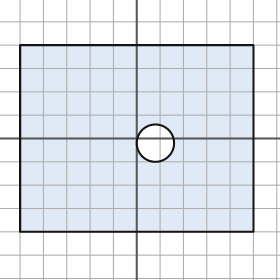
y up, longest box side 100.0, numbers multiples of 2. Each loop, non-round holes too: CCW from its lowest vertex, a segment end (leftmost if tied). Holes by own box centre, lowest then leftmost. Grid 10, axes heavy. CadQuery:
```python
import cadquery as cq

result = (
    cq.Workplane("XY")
    .moveTo(-50.0, -40.0)
    .lineTo(50.0, -40.0)
    .lineTo(50.0, 40.0)
    .lineTo(-50.0, 40.0)
    .close()
    .moveTo(8.0, -2.0)
    .circle(8.0)
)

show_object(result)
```